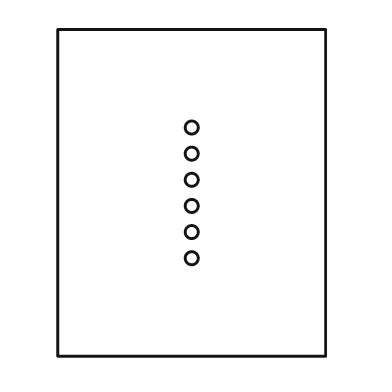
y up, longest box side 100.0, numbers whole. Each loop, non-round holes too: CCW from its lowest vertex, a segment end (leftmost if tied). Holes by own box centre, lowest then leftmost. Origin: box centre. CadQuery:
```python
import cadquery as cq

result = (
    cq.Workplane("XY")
    .moveTo(-41.0, -50.0)
    .lineTo(41.0, -50.0)
    .lineTo(41.0, 50.0)
    .lineTo(-41.0, 50.0)
    .close()
    .moveTo(0.0, -20.0)
    .circle(2.0)
    .moveTo(0.0, -12.0)
    .circle(2.0)
    .moveTo(0.0, -4.0)
    .circle(2.0)
    .moveTo(0.0, 4.0)
    .circle(2.0)
    .moveTo(0.0, 12.0)
    .circle(2.0)
    .moveTo(0.0, 20.0)
    .circle(2.0)
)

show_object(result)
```